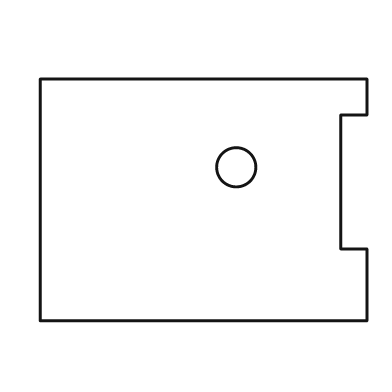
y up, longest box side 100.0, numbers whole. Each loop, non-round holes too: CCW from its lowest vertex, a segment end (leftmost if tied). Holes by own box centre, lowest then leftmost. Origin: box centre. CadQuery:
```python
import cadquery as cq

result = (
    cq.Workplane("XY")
    .moveTo(-50.0, -37.0)
    .lineTo(50.0, -37.0)
    .lineTo(50.0, -15.0)
    .lineTo(42.0, -15.0)
    .lineTo(42.0, 26.0)
    .lineTo(50.0, 26.0)
    .lineTo(50.0, 37.0)
    .lineTo(-50.0, 37.0)
    .close()
    .moveTo(10.0, 10.0)
    .circle(6.0)
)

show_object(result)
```